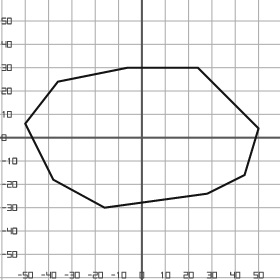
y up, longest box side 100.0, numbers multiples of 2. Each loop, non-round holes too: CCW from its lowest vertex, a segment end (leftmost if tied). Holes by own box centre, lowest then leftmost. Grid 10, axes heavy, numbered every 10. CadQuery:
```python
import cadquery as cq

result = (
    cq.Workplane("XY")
    .moveTo(-16.0, -30.0)
    .lineTo(28.0, -24.0)
    .lineTo(44.0, -16.0)
    .lineTo(50.0, 4.0)
    .lineTo(24.0, 30.0)
    .lineTo(-6.0, 30.0)
    .lineTo(-36.0, 24.0)
    .lineTo(-50.0, 6.0)
    .lineTo(-38.0, -18.0)
    .close()
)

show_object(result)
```